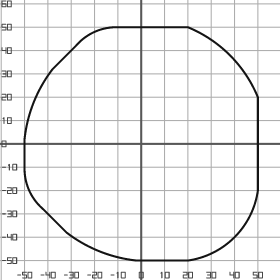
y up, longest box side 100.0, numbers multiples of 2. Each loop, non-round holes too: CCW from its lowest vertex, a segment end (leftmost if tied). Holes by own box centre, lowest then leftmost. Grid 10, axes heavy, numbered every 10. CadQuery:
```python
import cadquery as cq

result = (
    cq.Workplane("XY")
    .moveTo(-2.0, -50.0)
    .lineTo(20.0, -50.0)
    .threePointArc((40.0, -40.0), (50.0, -20.0))
    .lineTo(50.0, 20.0)
    .threePointArc((38.0, 38.0), (20.0, 50.0))
    .lineTo(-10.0, 50.0)
    .threePointArc((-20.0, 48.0), (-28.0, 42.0))
    .lineTo(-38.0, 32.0)
    .threePointArc((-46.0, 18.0), (-50.0, 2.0))
    .lineTo(-50.0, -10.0)
    .threePointArc((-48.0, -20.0), (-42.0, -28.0))
    .lineTo(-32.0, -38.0)
    .threePointArc((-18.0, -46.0), (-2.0, -50.0))
    .close()
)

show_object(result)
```